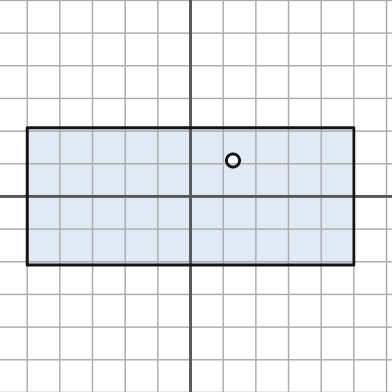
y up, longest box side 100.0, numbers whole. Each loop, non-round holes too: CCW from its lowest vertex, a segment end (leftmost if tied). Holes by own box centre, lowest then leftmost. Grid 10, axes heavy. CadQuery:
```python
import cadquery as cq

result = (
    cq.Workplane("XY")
    .moveTo(-50.0, -21.0)
    .lineTo(50.0, -21.0)
    .lineTo(50.0, 21.0)
    .lineTo(-50.0, 21.0)
    .close()
    .moveTo(13.0, 11.0)
    .circle(2.0)
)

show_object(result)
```